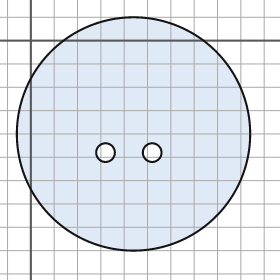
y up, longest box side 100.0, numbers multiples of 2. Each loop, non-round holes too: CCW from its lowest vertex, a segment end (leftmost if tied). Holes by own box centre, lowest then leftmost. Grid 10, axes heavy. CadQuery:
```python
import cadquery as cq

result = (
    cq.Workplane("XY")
    .moveTo(44.0, -40.0)
    .circle(50.0)
    .moveTo(32.0, -48.0)
    .circle(4.0)
    .moveTo(52.0, -48.0)
    .circle(4.0)
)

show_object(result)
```